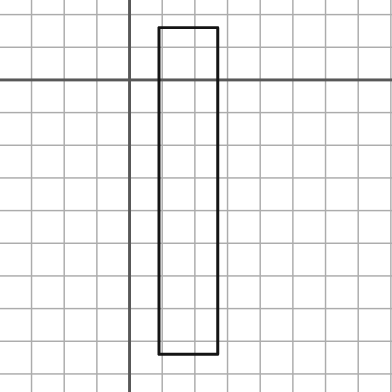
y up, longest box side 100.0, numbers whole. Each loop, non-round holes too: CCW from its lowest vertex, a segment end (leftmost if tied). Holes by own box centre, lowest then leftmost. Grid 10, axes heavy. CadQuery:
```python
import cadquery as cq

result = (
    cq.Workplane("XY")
    .moveTo(9.0, -84.0)
    .lineTo(27.0, -84.0)
    .lineTo(27.0, 16.0)
    .lineTo(9.0, 16.0)
    .close()
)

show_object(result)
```